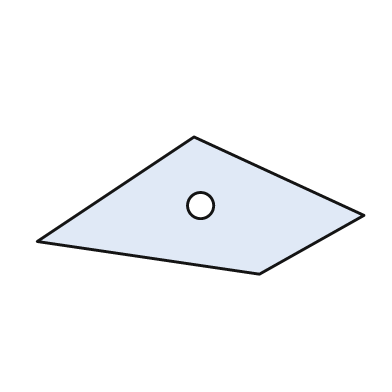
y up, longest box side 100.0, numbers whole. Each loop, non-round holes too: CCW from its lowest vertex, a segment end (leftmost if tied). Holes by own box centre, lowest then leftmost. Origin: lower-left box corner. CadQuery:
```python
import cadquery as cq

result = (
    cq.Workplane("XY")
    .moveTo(68.0, 0.0)
    .lineTo(100.0, 18.0)
    .lineTo(48.0, 42.0)
    .lineTo(0.0, 10.0)
    .close()
    .moveTo(50.0, 21.0)
    .circle(4.0)
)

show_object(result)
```